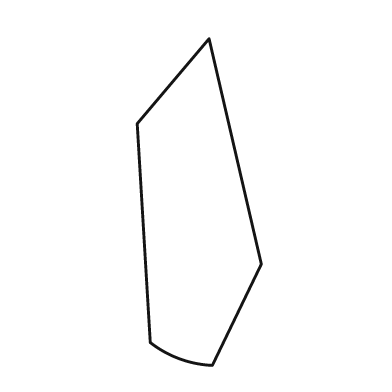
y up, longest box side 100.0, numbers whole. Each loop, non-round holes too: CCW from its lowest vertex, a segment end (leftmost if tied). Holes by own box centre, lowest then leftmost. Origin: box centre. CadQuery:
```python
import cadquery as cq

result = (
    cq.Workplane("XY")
    .moveTo(4.0, -50.0)
    .lineTo(19.0, -19.0)
    .lineTo(3.0, 50.0)
    .lineTo(-19.0, 24.0)
    .lineTo(-15.0, -43.0)
    .threePointArc((-6.0, -48.0), (4.0, -50.0))
    .close()
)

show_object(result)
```